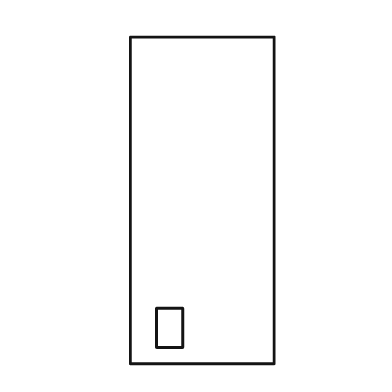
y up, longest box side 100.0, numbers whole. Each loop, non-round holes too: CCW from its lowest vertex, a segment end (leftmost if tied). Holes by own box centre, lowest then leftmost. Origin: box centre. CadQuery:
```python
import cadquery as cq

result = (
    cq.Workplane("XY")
    .moveTo(-22.0, -50.0)
    .lineTo(22.0, -50.0)
    .lineTo(22.0, 50.0)
    .lineTo(-22.0, 50.0)
    .close()
    .moveTo(-14.0, -45.0)
    .lineTo(-6.0, -45.0)
    .lineTo(-6.0, -33.0)
    .lineTo(-14.0, -33.0)
    .close()
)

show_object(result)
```